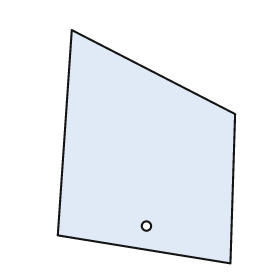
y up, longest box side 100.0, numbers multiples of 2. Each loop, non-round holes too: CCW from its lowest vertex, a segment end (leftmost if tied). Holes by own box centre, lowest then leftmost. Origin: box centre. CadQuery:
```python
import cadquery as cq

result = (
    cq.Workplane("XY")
    .moveTo(36.0, -50.0)
    .lineTo(38.0, 14.0)
    .lineTo(-32.0, 50.0)
    .lineTo(-38.0, -38.0)
    .close()
    .moveTo(0.0, -34.0)
    .circle(2.0)
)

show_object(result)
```